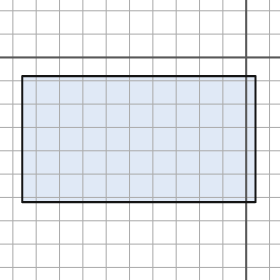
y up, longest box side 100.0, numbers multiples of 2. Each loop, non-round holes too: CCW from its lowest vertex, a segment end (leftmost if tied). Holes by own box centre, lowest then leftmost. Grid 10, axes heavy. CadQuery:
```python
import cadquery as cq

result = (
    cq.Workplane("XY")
    .moveTo(-96.0, -62.0)
    .lineTo(4.0, -62.0)
    .lineTo(4.0, -8.0)
    .lineTo(-96.0, -8.0)
    .close()
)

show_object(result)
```